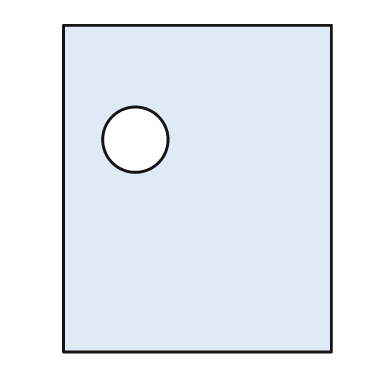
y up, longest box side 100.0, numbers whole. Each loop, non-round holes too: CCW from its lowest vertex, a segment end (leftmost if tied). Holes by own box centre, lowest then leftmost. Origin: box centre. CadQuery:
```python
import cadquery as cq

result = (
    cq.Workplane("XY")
    .moveTo(-41.0, -50.0)
    .lineTo(41.0, -50.0)
    .lineTo(41.0, 50.0)
    .lineTo(-41.0, 50.0)
    .close()
    .moveTo(-19.0, 15.0)
    .circle(10.0)
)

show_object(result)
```